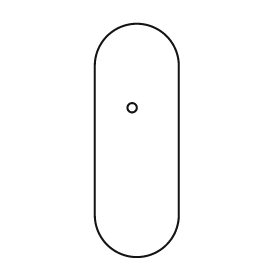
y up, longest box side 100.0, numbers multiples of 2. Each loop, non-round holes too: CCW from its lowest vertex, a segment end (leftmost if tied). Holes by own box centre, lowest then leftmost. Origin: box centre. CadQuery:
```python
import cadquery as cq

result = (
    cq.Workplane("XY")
    .moveTo(-18.0, -32.0)
    .threePointArc((0.0, -50.0), (18.0, -32.0))
    .lineTo(18.0, 32.0)
    .threePointArc((0.0, 50.0), (-18.0, 32.0))
    .close()
    .moveTo(-2.0, 14.0)
    .circle(2.0)
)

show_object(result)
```